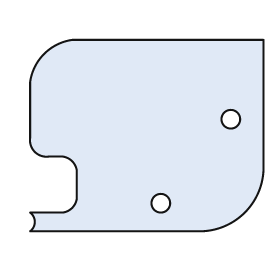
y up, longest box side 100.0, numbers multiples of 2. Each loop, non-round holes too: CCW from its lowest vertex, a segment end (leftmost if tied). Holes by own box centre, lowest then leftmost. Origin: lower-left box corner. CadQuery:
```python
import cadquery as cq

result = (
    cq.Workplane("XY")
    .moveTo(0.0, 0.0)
    .lineTo(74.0, 0.0)
    .threePointArc((92.0, 8.0), (100.0, 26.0))
    .lineTo(100.0, 82.0)
    .lineTo(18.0, 82.0)
    .threePointArc((6.0, 76.0), (0.0, 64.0))
    .lineTo(0.0, 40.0)
    .threePointArc((2.0, 34.0), (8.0, 32.0))
    .lineTo(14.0, 32.0)
    .threePointArc((18.0, 30.0), (20.0, 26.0))
    .lineTo(20.0, 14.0)
    .threePointArc((18.0, 10.0), (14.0, 8.0))
    .lineTo(0.0, 8.0)
    .threePointArc((2.0, 4.0), (0.0, 0.0))
    .close()
    .moveTo(56.0, 12.0)
    .circle(4.0)
    .moveTo(86.0, 48.0)
    .circle(4.0)
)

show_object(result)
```